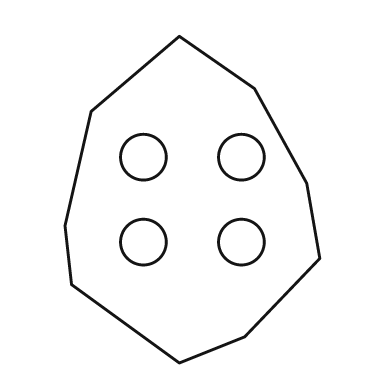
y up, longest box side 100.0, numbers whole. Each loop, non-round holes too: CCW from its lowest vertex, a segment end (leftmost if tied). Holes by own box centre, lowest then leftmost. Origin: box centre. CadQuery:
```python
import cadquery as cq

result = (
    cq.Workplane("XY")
    .moveTo(-4.0, -50.0)
    .lineTo(16.0, -42.0)
    .lineTo(39.0, -18.0)
    .lineTo(35.0, 5.0)
    .lineTo(19.0, 34.0)
    .lineTo(-4.0, 50.0)
    .lineTo(-31.0, 27.0)
    .lineTo(-39.0, -8.0)
    .lineTo(-37.0, -26.0)
    .close()
    .moveTo(-15.0, -13.0)
    .circle(7.0)
    .moveTo(15.0, -13.0)
    .circle(7.0)
    .moveTo(-15.0, 13.0)
    .circle(7.0)
    .moveTo(15.0, 13.0)
    .circle(7.0)
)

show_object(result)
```